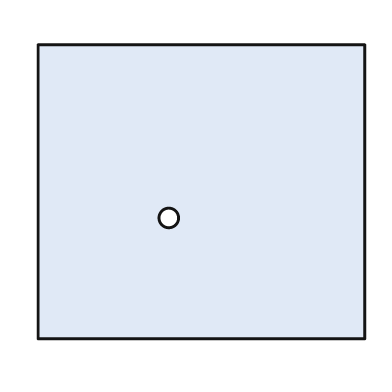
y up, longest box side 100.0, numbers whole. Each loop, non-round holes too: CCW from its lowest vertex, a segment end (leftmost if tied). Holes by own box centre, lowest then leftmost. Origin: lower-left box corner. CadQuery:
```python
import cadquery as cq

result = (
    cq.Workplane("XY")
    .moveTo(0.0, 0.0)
    .lineTo(100.0, 0.0)
    .lineTo(100.0, 90.0)
    .lineTo(0.0, 90.0)
    .close()
    .moveTo(40.0, 37.0)
    .circle(3.0)
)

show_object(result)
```